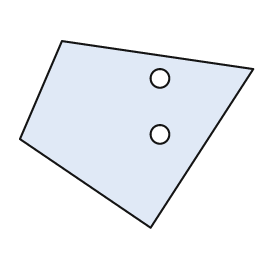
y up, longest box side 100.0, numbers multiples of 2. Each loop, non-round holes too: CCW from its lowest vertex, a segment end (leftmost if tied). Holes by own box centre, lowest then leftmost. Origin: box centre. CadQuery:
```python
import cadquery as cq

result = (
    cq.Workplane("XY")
    .moveTo(6.0, -40.0)
    .lineTo(50.0, 28.0)
    .lineTo(-32.0, 40.0)
    .lineTo(-50.0, -2.0)
    .close()
    .moveTo(10.0, 0.0)
    .circle(4.0)
    .moveTo(10.0, 24.0)
    .circle(4.0)
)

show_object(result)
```